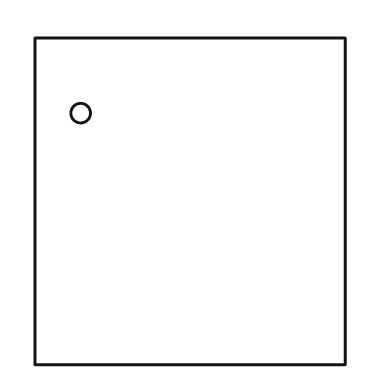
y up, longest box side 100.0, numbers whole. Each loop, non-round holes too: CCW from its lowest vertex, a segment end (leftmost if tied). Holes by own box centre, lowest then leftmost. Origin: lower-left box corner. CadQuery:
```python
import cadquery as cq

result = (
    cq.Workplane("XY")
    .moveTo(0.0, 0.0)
    .lineTo(95.0, 0.0)
    .lineTo(95.0, 100.0)
    .lineTo(0.0, 100.0)
    .close()
    .moveTo(14.0, 77.0)
    .circle(3.0)
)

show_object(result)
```